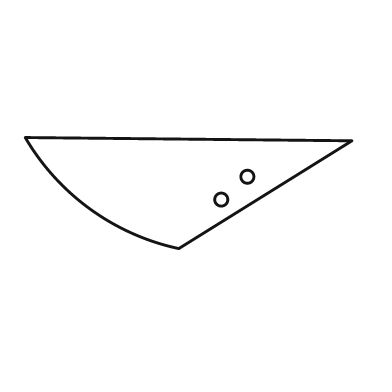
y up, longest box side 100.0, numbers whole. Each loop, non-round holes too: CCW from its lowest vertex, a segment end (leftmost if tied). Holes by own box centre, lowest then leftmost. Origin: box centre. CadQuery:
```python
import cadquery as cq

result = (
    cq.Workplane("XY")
    .moveTo(-3.0, -17.0)
    .lineTo(50.0, 16.0)
    .lineTo(-50.0, 17.0)
    .threePointArc((-30.0, -5.0), (-3.0, -17.0))
    .close()
    .moveTo(10.0, -2.0)
    .circle(2.0)
    .moveTo(18.0, 5.0)
    .circle(2.0)
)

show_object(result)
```